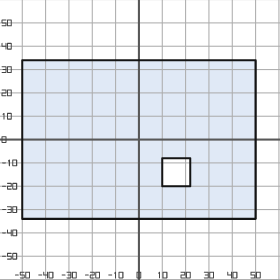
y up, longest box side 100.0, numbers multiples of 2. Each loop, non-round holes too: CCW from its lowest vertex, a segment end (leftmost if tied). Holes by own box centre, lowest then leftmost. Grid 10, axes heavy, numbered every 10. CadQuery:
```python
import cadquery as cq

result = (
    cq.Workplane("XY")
    .moveTo(-50.0, -34.0)
    .lineTo(50.0, -34.0)
    .lineTo(50.0, 34.0)
    .lineTo(-50.0, 34.0)
    .close()
    .moveTo(10.0, -20.0)
    .lineTo(22.0, -20.0)
    .lineTo(22.0, -8.0)
    .lineTo(10.0, -8.0)
    .close()
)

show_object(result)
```